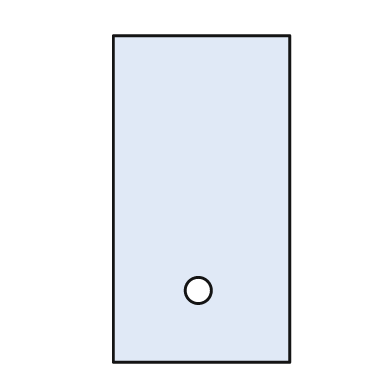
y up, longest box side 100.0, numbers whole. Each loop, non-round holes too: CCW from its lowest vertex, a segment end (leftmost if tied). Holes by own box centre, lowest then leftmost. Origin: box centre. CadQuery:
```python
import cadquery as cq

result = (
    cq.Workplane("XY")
    .moveTo(-27.0, -50.0)
    .lineTo(27.0, -50.0)
    .lineTo(27.0, 50.0)
    .lineTo(-27.0, 50.0)
    .close()
    .moveTo(-1.0, -28.0)
    .circle(4.0)
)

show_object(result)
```